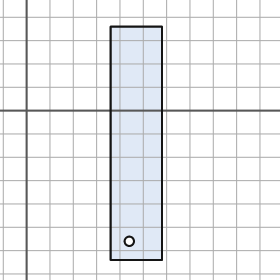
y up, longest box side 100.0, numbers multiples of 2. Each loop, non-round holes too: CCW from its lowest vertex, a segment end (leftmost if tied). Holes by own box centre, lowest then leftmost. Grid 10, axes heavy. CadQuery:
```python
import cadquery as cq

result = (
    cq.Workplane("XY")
    .moveTo(36.0, -64.0)
    .lineTo(58.0, -64.0)
    .lineTo(58.0, 36.0)
    .lineTo(36.0, 36.0)
    .close()
    .moveTo(44.0, -56.0)
    .circle(2.0)
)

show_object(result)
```